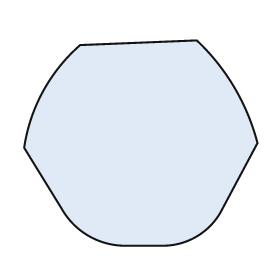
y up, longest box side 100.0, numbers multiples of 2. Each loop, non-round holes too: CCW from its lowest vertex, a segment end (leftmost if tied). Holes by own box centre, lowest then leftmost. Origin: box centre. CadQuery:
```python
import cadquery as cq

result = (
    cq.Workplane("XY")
    .moveTo(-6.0, -44.0)
    .lineTo(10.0, -44.0)
    .threePointArc((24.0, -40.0), (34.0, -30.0))
    .lineTo(50.0, 0.0)
    .threePointArc((40.0, 24.0), (24.0, 44.0))
    .lineTo(-26.0, 42.0)
    .threePointArc((-42.0, 22.0), (-50.0, -2.0))
    .lineTo(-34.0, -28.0)
    .threePointArc((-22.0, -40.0), (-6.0, -44.0))
    .close()
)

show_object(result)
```